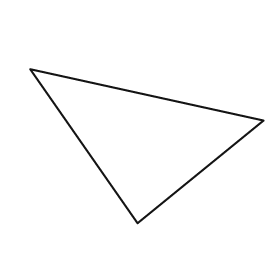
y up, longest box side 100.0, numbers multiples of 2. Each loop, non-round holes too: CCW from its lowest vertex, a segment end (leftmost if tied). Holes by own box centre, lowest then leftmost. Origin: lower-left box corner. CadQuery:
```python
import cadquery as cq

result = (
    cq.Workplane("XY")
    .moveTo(46.0, 0.0)
    .lineTo(100.0, 44.0)
    .lineTo(0.0, 66.0)
    .close()
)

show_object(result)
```